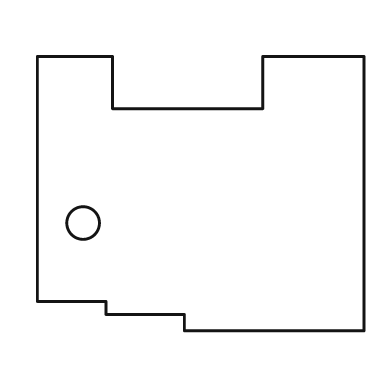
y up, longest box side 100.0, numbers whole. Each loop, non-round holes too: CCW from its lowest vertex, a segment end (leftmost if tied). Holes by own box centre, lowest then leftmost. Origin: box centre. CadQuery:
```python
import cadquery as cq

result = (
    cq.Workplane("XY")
    .moveTo(-5.0, -42.0)
    .lineTo(50.0, -42.0)
    .lineTo(50.0, 42.0)
    .lineTo(19.0, 42.0)
    .lineTo(19.0, 26.0)
    .lineTo(-27.0, 26.0)
    .lineTo(-27.0, 42.0)
    .lineTo(-50.0, 42.0)
    .lineTo(-50.0, -33.0)
    .lineTo(-29.0, -33.0)
    .lineTo(-29.0, -37.0)
    .lineTo(-5.0, -37.0)
    .close()
    .moveTo(-36.0, -9.0)
    .circle(5.0)
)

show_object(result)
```